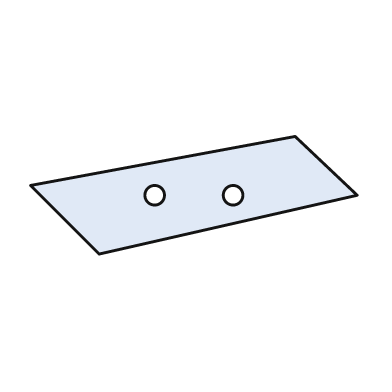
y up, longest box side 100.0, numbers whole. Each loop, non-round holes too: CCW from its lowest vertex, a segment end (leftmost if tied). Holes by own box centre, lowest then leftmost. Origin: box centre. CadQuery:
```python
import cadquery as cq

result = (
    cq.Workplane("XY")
    .moveTo(-29.0, -18.0)
    .lineTo(50.0, 0.0)
    .lineTo(31.0, 18.0)
    .lineTo(-50.0, 3.0)
    .close()
    .moveTo(-12.0, 0.0)
    .circle(3.0)
    .moveTo(12.0, 0.0)
    .circle(3.0)
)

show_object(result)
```